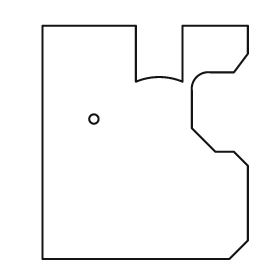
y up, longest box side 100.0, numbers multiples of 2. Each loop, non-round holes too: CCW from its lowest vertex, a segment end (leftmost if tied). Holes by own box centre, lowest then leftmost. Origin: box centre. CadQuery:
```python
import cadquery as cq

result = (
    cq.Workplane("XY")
    .moveTo(-44.0, -50.0)
    .lineTo(36.0, -50.0)
    .lineTo(44.0, -42.0)
    .lineTo(44.0, -10.0)
    .lineTo(38.0, -4.0)
    .lineTo(30.0, -4.0)
    .lineTo(20.0, 6.0)
    .lineTo(20.0, 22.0)
    .threePointArc((22.0, 28.0), (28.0, 30.0))
    .lineTo(38.0, 30.0)
    .lineTo(44.0, 38.0)
    .lineTo(44.0, 50.0)
    .lineTo(16.0, 50.0)
    .lineTo(16.0, 26.0)
    .threePointArc((6.0, 28.0), (-4.0, 26.0))
    .lineTo(-4.0, 50.0)
    .lineTo(-44.0, 50.0)
    .close()
    .moveTo(-22.0, 10.0)
    .circle(2.0)
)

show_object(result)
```